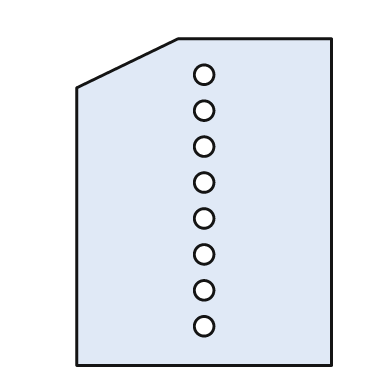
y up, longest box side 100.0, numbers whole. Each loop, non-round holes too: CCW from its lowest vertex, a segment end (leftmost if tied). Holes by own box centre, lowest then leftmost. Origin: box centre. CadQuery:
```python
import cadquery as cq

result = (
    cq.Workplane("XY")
    .moveTo(-39.0, -50.0)
    .lineTo(39.0, -50.0)
    .lineTo(39.0, 50.0)
    .lineTo(-8.0, 50.0)
    .lineTo(-39.0, 35.0)
    .close()
    .moveTo(0.0, -38.0)
    .circle(3.0)
    .moveTo(0.0, -27.0)
    .circle(3.0)
    .moveTo(0.0, -16.0)
    .circle(3.0)
    .moveTo(0.0, -5.0)
    .circle(3.0)
    .moveTo(0.0, 6.0)
    .circle(3.0)
    .moveTo(0.0, 17.0)
    .circle(3.0)
    .moveTo(0.0, 28.0)
    .circle(3.0)
    .moveTo(0.0, 39.0)
    .circle(3.0)
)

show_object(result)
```